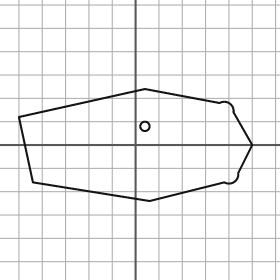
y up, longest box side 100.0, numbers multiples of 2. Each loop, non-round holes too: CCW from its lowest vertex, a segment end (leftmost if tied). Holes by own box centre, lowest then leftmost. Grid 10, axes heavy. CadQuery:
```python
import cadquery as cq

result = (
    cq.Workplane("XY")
    .moveTo(6.0, -24.0)
    .lineTo(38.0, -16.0)
    .threePointArc((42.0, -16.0), (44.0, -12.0))
    .lineTo(50.0, 0.0)
    .lineTo(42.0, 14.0)
    .threePointArc((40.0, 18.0), (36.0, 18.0))
    .lineTo(4.0, 24.0)
    .lineTo(-50.0, 12.0)
    .lineTo(-44.0, -16.0)
    .close()
    .moveTo(4.0, 8.0)
    .circle(2.0)
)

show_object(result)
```